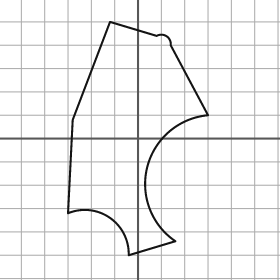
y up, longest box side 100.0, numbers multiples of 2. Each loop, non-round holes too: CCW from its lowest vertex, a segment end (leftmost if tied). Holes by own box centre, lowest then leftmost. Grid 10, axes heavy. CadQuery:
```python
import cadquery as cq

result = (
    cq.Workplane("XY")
    .moveTo(-4.0, -50.0)
    .lineTo(16.0, -44.0)
    .threePointArc((4.0, -12.0), (30.0, 10.0))
    .lineTo(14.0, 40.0)
    .threePointArc((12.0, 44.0), (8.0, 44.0))
    .lineTo(-12.0, 50.0)
    .lineTo(-28.0, 8.0)
    .lineTo(-30.0, -32.0)
    .threePointArc((-12.0, -34.0), (-4.0, -50.0))
    .close()
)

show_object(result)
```